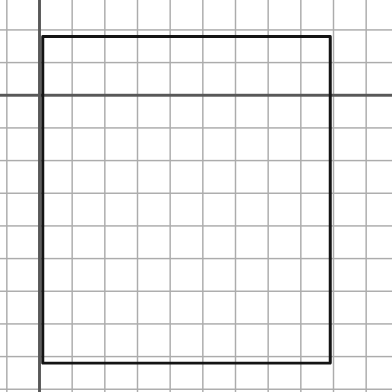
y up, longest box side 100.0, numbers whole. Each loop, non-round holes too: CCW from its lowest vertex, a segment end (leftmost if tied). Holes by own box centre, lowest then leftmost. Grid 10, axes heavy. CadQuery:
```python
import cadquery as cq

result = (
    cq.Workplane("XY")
    .moveTo(1.0, -82.0)
    .lineTo(89.0, -82.0)
    .lineTo(89.0, 18.0)
    .lineTo(1.0, 18.0)
    .close()
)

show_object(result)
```